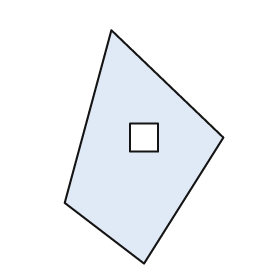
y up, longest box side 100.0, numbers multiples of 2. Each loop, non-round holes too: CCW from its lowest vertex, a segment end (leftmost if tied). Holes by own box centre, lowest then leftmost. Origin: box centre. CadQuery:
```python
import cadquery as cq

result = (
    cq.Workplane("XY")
    .moveTo(0.0, -50.0)
    .lineTo(34.0, 4.0)
    .lineTo(-14.0, 50.0)
    .lineTo(-34.0, -24.0)
    .close()
    .moveTo(-6.0, -2.0)
    .lineTo(6.0, -2.0)
    .lineTo(6.0, 10.0)
    .lineTo(-6.0, 10.0)
    .close()
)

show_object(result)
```